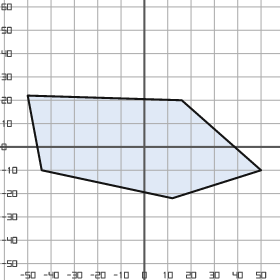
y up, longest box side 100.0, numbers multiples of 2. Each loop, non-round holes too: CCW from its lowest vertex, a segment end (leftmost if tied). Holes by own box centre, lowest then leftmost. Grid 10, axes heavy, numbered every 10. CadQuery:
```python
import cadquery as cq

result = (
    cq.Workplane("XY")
    .moveTo(12.0, -22.0)
    .lineTo(50.0, -10.0)
    .lineTo(16.0, 20.0)
    .lineTo(-50.0, 22.0)
    .lineTo(-44.0, -10.0)
    .close()
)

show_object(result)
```